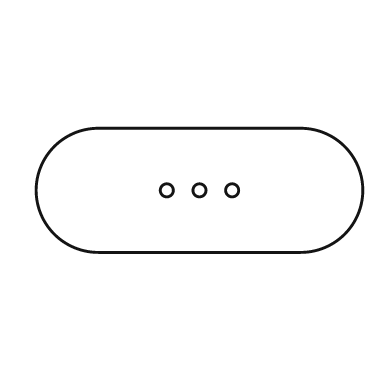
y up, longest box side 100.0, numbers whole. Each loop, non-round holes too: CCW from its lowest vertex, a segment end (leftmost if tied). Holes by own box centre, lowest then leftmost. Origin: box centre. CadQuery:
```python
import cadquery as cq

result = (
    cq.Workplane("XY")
    .moveTo(-31.0, -19.0)
    .lineTo(31.0, -19.0)
    .threePointArc((50.0, 0.0), (31.0, 19.0))
    .lineTo(-31.0, 19.0)
    .threePointArc((-50.0, 0.0), (-31.0, -19.0))
    .close()
    .moveTo(-10.0, 0.0)
    .circle(2.0)
    .moveTo(0.0, 0.0)
    .circle(2.0)
    .moveTo(10.0, 0.0)
    .circle(2.0)
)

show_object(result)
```